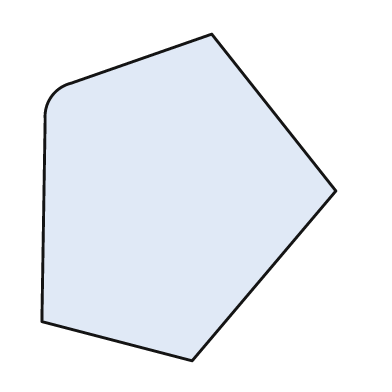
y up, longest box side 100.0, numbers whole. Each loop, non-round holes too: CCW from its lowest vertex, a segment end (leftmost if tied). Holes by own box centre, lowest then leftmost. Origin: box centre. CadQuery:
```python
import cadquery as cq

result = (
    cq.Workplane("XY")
    .moveTo(1.0, -50.0)
    .lineTo(45.0, 2.0)
    .lineTo(7.0, 50.0)
    .lineTo(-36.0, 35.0)
    .threePointArc((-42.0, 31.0), (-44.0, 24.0))
    .lineTo(-45.0, -38.0)
    .close()
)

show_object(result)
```